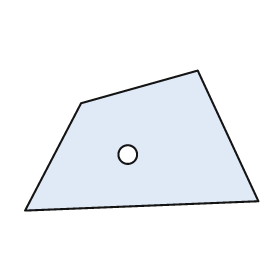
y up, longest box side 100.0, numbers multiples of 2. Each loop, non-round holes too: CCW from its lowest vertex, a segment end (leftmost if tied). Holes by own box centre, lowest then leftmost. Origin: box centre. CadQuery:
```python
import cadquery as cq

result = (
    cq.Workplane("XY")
    .moveTo(-50.0, -30.0)
    .lineTo(50.0, -26.0)
    .lineTo(24.0, 30.0)
    .lineTo(-26.0, 16.0)
    .close()
    .moveTo(-6.0, -6.0)
    .circle(4.0)
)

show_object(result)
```